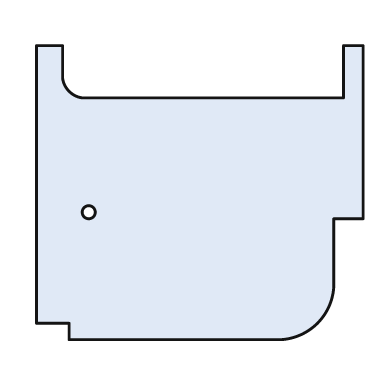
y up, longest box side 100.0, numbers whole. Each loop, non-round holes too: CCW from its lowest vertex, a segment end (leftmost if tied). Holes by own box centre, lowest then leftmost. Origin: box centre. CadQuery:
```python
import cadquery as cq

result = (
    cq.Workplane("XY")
    .moveTo(-40.0, -45.0)
    .lineTo(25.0, -45.0)
    .threePointArc((36.0, -40.0), (41.0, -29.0))
    .lineTo(41.0, -8.0)
    .lineTo(50.0, -8.0)
    .lineTo(50.0, 45.0)
    .lineTo(44.0, 45.0)
    .lineTo(44.0, 29.0)
    .lineTo(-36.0, 29.0)
    .threePointArc((-40.0, 31.0), (-42.0, 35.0))
    .lineTo(-42.0, 45.0)
    .lineTo(-50.0, 45.0)
    .lineTo(-50.0, -40.0)
    .lineTo(-40.0, -40.0)
    .close()
    .moveTo(-34.0, -6.0)
    .circle(2.0)
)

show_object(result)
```